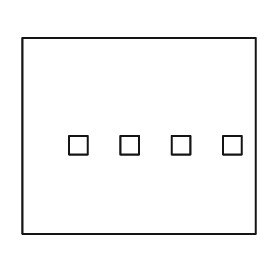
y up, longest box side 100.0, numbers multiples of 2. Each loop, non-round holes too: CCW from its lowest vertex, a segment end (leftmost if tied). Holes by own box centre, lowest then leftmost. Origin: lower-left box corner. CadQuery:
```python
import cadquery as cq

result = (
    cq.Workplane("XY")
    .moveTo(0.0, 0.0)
    .lineTo(100.0, 0.0)
    .lineTo(100.0, 84.0)
    .lineTo(0.0, 84.0)
    .close()
    .moveTo(20.0, 34.0)
    .lineTo(28.0, 34.0)
    .lineTo(28.0, 42.0)
    .lineTo(20.0, 42.0)
    .close()
    .moveTo(42.0, 34.0)
    .lineTo(50.0, 34.0)
    .lineTo(50.0, 42.0)
    .lineTo(42.0, 42.0)
    .close()
    .moveTo(64.0, 34.0)
    .lineTo(72.0, 34.0)
    .lineTo(72.0, 42.0)
    .lineTo(64.0, 42.0)
    .close()
    .moveTo(86.0, 34.0)
    .lineTo(94.0, 34.0)
    .lineTo(94.0, 42.0)
    .lineTo(86.0, 42.0)
    .close()
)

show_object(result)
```